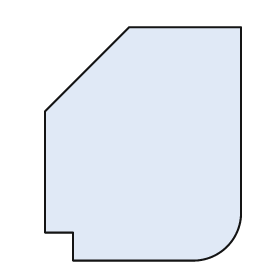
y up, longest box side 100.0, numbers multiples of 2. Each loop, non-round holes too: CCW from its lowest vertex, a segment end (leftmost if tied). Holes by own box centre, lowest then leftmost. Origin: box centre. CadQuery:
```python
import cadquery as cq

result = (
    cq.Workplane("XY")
    .moveTo(-30.0, -50.0)
    .lineTo(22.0, -50.0)
    .threePointArc((36.0, -44.0), (42.0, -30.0))
    .lineTo(42.0, 50.0)
    .lineTo(-6.0, 50.0)
    .lineTo(-42.0, 14.0)
    .lineTo(-42.0, -38.0)
    .lineTo(-30.0, -38.0)
    .close()
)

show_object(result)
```